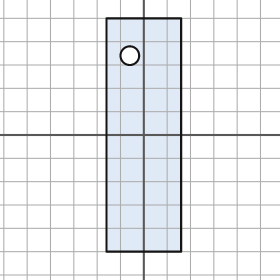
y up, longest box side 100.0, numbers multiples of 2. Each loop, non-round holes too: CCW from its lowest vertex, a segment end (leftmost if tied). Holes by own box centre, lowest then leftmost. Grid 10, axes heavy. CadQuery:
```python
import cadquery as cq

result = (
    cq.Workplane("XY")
    .moveTo(-16.0, -50.0)
    .lineTo(16.0, -50.0)
    .lineTo(16.0, 50.0)
    .lineTo(-16.0, 50.0)
    .close()
    .moveTo(-6.0, 34.0)
    .circle(4.0)
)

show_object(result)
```